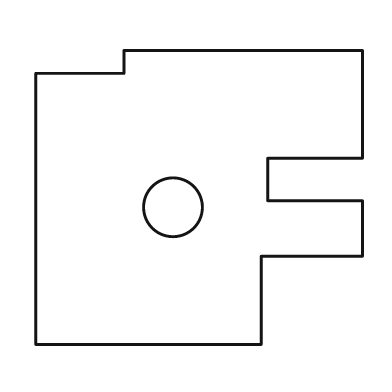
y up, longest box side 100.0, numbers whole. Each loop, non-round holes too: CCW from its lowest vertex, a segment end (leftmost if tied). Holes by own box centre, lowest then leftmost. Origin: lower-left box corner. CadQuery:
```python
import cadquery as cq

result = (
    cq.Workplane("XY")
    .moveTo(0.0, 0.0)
    .lineTo(69.0, 0.0)
    .lineTo(69.0, 27.0)
    .lineTo(100.0, 27.0)
    .lineTo(100.0, 44.0)
    .lineTo(71.0, 44.0)
    .lineTo(71.0, 57.0)
    .lineTo(100.0, 57.0)
    .lineTo(100.0, 90.0)
    .lineTo(27.0, 90.0)
    .lineTo(27.0, 83.0)
    .lineTo(0.0, 83.0)
    .close()
    .moveTo(42.0, 42.0)
    .circle(9.0)
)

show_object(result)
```